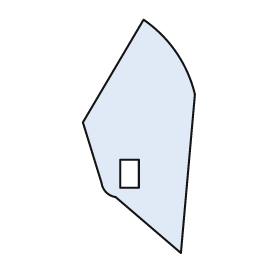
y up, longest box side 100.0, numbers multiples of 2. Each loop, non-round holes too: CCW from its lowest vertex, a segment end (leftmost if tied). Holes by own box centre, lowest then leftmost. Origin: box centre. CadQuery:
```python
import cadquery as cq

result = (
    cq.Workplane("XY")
    .moveTo(18.0, -50.0)
    .lineTo(24.0, 18.0)
    .threePointArc((16.0, 36.0), (2.0, 50.0))
    .lineTo(-24.0, 6.0)
    .lineTo(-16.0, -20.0)
    .threePointArc((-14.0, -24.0), (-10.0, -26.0))
    .close()
    .moveTo(-8.0, -22.0)
    .lineTo(0.0, -22.0)
    .lineTo(0.0, -10.0)
    .lineTo(-8.0, -10.0)
    .close()
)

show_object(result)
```